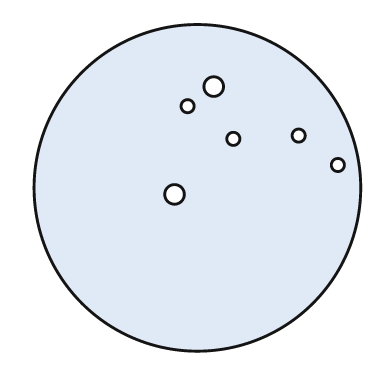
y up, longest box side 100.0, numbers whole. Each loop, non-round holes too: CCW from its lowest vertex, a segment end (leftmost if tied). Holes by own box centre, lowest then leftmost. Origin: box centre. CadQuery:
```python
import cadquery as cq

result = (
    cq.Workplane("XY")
    .moveTo(0.0, 0.0)
    .circle(50.0)
    .moveTo(-7.0, -2.0)
    .circle(3.0)
    .moveTo(43.0, 7.0)
    .circle(2.0)
    .moveTo(11.0, 15.0)
    .circle(2.0)
    .moveTo(31.0, 16.0)
    .circle(2.0)
    .moveTo(-3.0, 25.0)
    .circle(2.0)
    .moveTo(5.0, 31.0)
    .circle(3.0)
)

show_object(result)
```